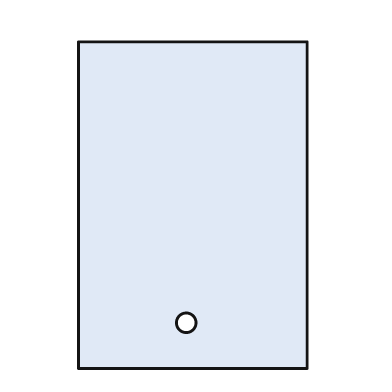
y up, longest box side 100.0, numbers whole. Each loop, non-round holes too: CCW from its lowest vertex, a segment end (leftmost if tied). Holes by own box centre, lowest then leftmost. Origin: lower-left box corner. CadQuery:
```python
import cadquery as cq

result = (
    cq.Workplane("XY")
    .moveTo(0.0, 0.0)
    .lineTo(70.0, 0.0)
    .lineTo(70.0, 100.0)
    .lineTo(0.0, 100.0)
    .close()
    .moveTo(33.0, 14.0)
    .circle(3.0)
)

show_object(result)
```